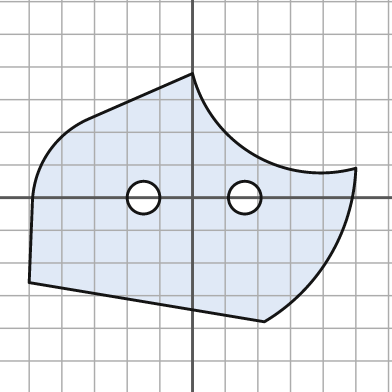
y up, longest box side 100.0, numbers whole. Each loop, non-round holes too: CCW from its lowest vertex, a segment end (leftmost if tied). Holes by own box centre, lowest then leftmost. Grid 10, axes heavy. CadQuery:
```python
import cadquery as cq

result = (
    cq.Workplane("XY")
    .moveTo(22.0, -38.0)
    .threePointArc((42.0, -18.0), (50.0, 9.0))
    .threePointArc((19.0, 13.0), (0.0, 38.0))
    .lineTo(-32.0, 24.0)
    .threePointArc((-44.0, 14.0), (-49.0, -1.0))
    .lineTo(-50.0, -26.0)
    .close()
    .moveTo(-15.0, 0.0)
    .circle(5.0)
    .moveTo(16.0, 0.0)
    .circle(5.0)
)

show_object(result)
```